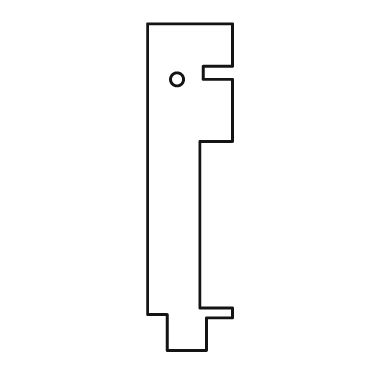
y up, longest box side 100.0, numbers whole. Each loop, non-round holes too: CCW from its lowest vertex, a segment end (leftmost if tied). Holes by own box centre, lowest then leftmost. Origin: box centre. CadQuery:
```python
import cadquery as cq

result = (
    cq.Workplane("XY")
    .moveTo(-7.0, -50.0)
    .lineTo(5.0, -50.0)
    .lineTo(5.0, -40.0)
    .lineTo(13.0, -40.0)
    .lineTo(13.0, -37.0)
    .lineTo(3.0, -37.0)
    .lineTo(3.0, 14.0)
    .lineTo(13.0, 14.0)
    .lineTo(13.0, 33.0)
    .lineTo(4.0, 33.0)
    .lineTo(4.0, 37.0)
    .lineTo(13.0, 37.0)
    .lineTo(13.0, 50.0)
    .lineTo(-13.0, 50.0)
    .lineTo(-13.0, -39.0)
    .lineTo(-7.0, -39.0)
    .close()
    .moveTo(-4.0, 33.0)
    .circle(2.0)
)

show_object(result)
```